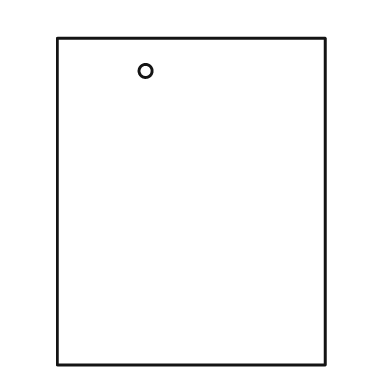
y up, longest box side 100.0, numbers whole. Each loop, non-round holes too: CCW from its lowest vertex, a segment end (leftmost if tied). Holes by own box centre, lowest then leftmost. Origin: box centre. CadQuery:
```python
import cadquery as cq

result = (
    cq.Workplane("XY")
    .moveTo(-41.0, -50.0)
    .lineTo(41.0, -50.0)
    .lineTo(41.0, 50.0)
    .lineTo(-41.0, 50.0)
    .close()
    .moveTo(-14.0, 40.0)
    .circle(2.0)
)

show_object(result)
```